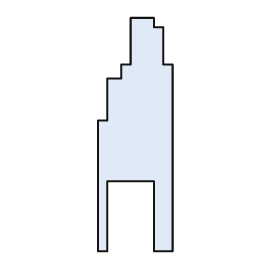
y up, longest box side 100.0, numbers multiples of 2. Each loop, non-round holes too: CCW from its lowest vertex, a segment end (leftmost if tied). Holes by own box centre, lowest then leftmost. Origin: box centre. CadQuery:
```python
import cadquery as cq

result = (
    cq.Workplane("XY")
    .moveTo(-16.0, -50.0)
    .lineTo(-12.0, -50.0)
    .lineTo(-12.0, -20.0)
    .lineTo(8.0, -20.0)
    .lineTo(8.0, -50.0)
    .lineTo(16.0, -50.0)
    .lineTo(16.0, 30.0)
    .lineTo(12.0, 30.0)
    .lineTo(12.0, 46.0)
    .lineTo(8.0, 46.0)
    .lineTo(8.0, 50.0)
    .lineTo(-2.0, 50.0)
    .lineTo(-2.0, 30.0)
    .lineTo(-6.0, 30.0)
    .lineTo(-6.0, 24.0)
    .lineTo(-12.0, 24.0)
    .lineTo(-12.0, 6.0)
    .lineTo(-16.0, 6.0)
    .close()
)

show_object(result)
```